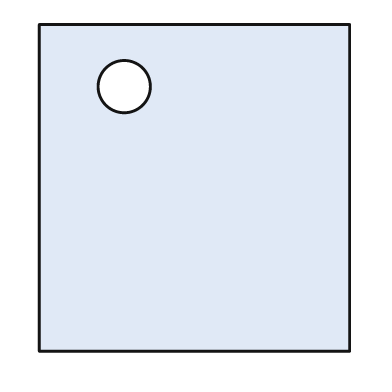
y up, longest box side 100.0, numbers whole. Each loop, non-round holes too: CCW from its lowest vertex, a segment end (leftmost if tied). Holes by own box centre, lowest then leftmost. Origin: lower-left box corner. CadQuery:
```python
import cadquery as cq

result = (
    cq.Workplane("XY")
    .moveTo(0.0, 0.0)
    .lineTo(95.0, 0.0)
    .lineTo(95.0, 100.0)
    .lineTo(0.0, 100.0)
    .close()
    .moveTo(26.0, 81.0)
    .circle(8.0)
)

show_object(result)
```